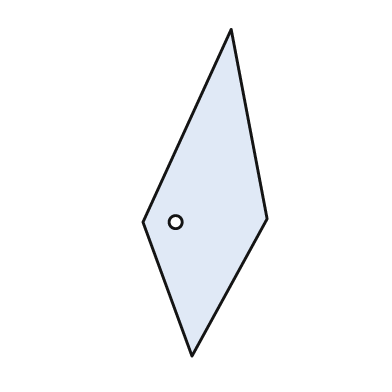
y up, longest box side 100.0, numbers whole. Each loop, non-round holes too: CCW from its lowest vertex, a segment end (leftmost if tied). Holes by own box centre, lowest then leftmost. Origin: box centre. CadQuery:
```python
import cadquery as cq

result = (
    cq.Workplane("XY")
    .moveTo(-4.0, -50.0)
    .lineTo(19.0, -8.0)
    .lineTo(8.0, 50.0)
    .lineTo(-19.0, -9.0)
    .close()
    .moveTo(-9.0, -9.0)
    .circle(2.0)
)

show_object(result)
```